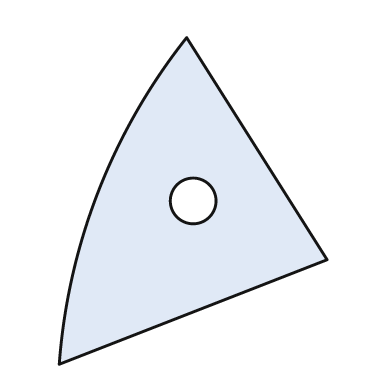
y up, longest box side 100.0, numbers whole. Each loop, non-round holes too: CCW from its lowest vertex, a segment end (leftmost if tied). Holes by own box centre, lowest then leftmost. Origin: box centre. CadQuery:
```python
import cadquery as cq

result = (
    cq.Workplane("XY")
    .moveTo(-41.0, -50.0)
    .lineTo(41.0, -18.0)
    .lineTo(-2.0, 50.0)
    .threePointArc((-29.0, 3.0), (-41.0, -50.0))
    .close()
    .moveTo(0.0, 0.0)
    .circle(7.0)
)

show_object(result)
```